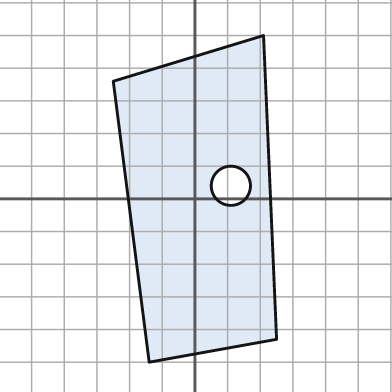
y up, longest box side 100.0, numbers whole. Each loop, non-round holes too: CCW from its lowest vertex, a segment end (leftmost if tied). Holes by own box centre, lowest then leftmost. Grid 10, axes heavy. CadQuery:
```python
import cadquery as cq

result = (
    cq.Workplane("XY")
    .moveTo(-14.0, -50.0)
    .lineTo(25.0, -43.0)
    .lineTo(21.0, 50.0)
    .lineTo(-25.0, 36.0)
    .close()
    .moveTo(11.0, 4.0)
    .circle(6.0)
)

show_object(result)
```